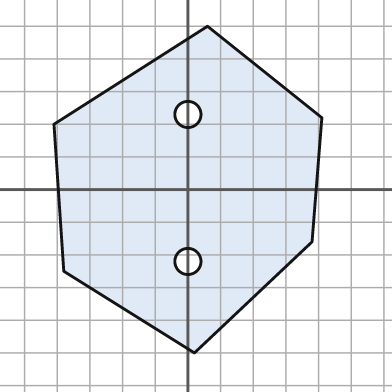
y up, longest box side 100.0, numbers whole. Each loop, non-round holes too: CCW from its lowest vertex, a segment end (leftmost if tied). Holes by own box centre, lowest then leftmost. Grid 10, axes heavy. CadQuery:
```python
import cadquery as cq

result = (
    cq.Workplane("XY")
    .moveTo(2.0, -50.0)
    .lineTo(38.0, -16.0)
    .lineTo(41.0, 22.0)
    .lineTo(6.0, 50.0)
    .lineTo(-41.0, 20.0)
    .lineTo(-38.0, -25.0)
    .close()
    .moveTo(0.0, -22.0)
    .circle(4.0)
    .moveTo(0.0, 23.0)
    .circle(4.0)
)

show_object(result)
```